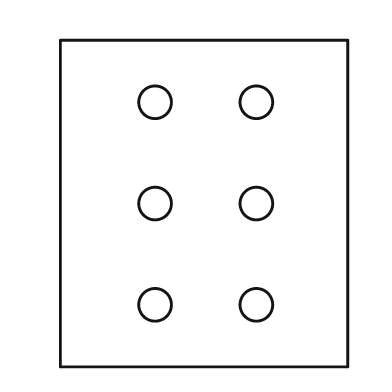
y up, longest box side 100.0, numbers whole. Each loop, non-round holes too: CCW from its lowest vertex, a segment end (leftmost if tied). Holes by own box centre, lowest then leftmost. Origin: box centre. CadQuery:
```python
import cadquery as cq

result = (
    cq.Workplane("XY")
    .moveTo(-44.0, -50.0)
    .lineTo(44.0, -50.0)
    .lineTo(44.0, 50.0)
    .lineTo(-44.0, 50.0)
    .close()
    .moveTo(-15.0, -31.0)
    .circle(5.0)
    .moveTo(16.0, -31.0)
    .circle(5.0)
    .moveTo(-15.0, 0.0)
    .circle(5.0)
    .moveTo(16.0, 0.0)
    .circle(5.0)
    .moveTo(-15.0, 31.0)
    .circle(5.0)
    .moveTo(16.0, 31.0)
    .circle(5.0)
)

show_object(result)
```